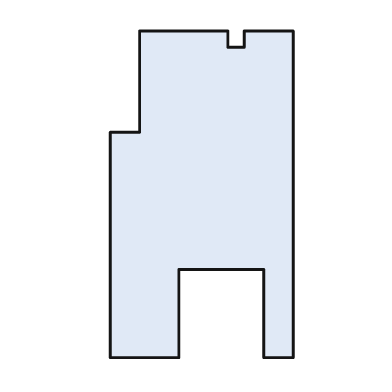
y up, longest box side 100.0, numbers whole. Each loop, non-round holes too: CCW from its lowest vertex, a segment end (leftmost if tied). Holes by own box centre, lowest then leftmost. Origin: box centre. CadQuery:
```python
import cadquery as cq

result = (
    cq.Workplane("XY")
    .moveTo(-28.0, -50.0)
    .lineTo(-7.0, -50.0)
    .lineTo(-7.0, -23.0)
    .lineTo(19.0, -23.0)
    .lineTo(19.0, -50.0)
    .lineTo(28.0, -50.0)
    .lineTo(28.0, 50.0)
    .lineTo(13.0, 50.0)
    .lineTo(13.0, 45.0)
    .lineTo(8.0, 45.0)
    .lineTo(8.0, 50.0)
    .lineTo(-19.0, 50.0)
    .lineTo(-19.0, 19.0)
    .lineTo(-28.0, 19.0)
    .close()
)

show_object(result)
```